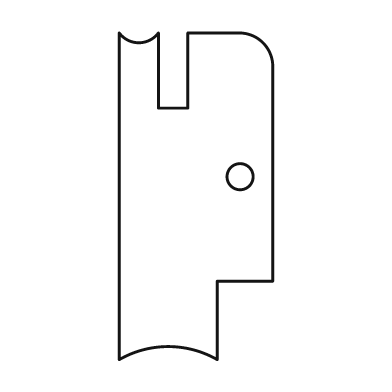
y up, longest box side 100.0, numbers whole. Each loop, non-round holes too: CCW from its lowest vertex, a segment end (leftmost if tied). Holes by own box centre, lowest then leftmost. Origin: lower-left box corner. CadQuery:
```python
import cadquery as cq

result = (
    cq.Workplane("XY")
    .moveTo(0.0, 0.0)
    .threePointArc((15.0, 4.0), (30.0, 0.0))
    .lineTo(30.0, 24.0)
    .lineTo(47.0, 24.0)
    .lineTo(47.0, 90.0)
    .threePointArc((44.0, 97.0), (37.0, 100.0))
    .lineTo(21.0, 100.0)
    .lineTo(21.0, 77.0)
    .lineTo(12.0, 77.0)
    .lineTo(12.0, 100.0)
    .threePointArc((6.0, 97.0), (0.0, 100.0))
    .close()
    .moveTo(37.0, 56.0)
    .circle(4.0)
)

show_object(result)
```